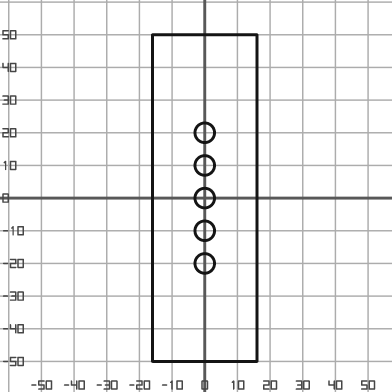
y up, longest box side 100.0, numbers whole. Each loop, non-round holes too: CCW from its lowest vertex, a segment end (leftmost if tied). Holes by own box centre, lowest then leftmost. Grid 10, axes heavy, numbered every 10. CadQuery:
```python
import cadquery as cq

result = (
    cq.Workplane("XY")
    .moveTo(-16.0, -50.0)
    .lineTo(16.0, -50.0)
    .lineTo(16.0, 50.0)
    .lineTo(-16.0, 50.0)
    .close()
    .moveTo(0.0, -20.0)
    .circle(3.0)
    .moveTo(0.0, -10.0)
    .circle(3.0)
    .moveTo(0.0, 0.0)
    .circle(3.0)
    .moveTo(0.0, 10.0)
    .circle(3.0)
    .moveTo(0.0, 20.0)
    .circle(3.0)
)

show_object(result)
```